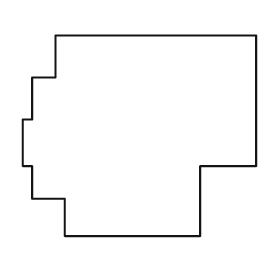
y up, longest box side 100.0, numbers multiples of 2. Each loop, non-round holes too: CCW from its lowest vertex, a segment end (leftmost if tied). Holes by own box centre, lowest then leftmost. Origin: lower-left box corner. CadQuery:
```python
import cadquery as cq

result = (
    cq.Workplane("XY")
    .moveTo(18.0, 0.0)
    .lineTo(76.0, 0.0)
    .lineTo(76.0, 30.0)
    .lineTo(100.0, 30.0)
    .lineTo(100.0, 86.0)
    .lineTo(14.0, 86.0)
    .lineTo(14.0, 68.0)
    .lineTo(4.0, 68.0)
    .lineTo(4.0, 50.0)
    .lineTo(0.0, 50.0)
    .lineTo(0.0, 30.0)
    .lineTo(4.0, 30.0)
    .lineTo(4.0, 16.0)
    .lineTo(18.0, 16.0)
    .close()
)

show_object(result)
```